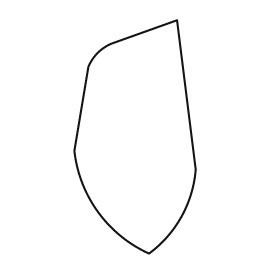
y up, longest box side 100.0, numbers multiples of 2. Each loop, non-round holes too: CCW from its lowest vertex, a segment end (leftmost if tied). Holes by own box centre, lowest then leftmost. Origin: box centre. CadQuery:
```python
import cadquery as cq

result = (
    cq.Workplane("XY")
    .moveTo(6.0, -50.0)
    .threePointArc((20.0, -34.0), (26.0, -14.0))
    .lineTo(18.0, 50.0)
    .lineTo(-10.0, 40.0)
    .threePointArc((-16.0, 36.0), (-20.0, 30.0))
    .lineTo(-26.0, -6.0)
    .threePointArc((-16.0, -32.0), (6.0, -50.0))
    .close()
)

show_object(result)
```